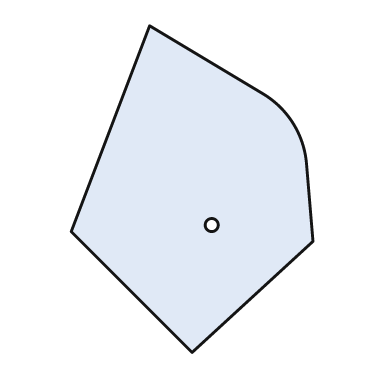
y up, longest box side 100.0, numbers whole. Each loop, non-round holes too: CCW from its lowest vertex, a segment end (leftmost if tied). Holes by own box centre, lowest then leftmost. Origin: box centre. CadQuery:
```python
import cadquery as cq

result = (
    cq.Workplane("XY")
    .moveTo(0.0, -50.0)
    .lineTo(37.0, -16.0)
    .lineTo(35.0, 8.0)
    .threePointArc((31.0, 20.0), (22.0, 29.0))
    .lineTo(-13.0, 50.0)
    .lineTo(-37.0, -13.0)
    .close()
    .moveTo(6.0, -11.0)
    .circle(2.0)
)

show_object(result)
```